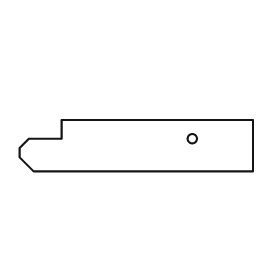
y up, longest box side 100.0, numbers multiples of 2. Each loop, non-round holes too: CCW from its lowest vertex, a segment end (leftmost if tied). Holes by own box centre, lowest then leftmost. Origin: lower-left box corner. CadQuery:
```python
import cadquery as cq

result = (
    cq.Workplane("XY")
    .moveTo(6.0, 0.0)
    .lineTo(100.0, 0.0)
    .lineTo(100.0, 22.0)
    .lineTo(18.0, 22.0)
    .lineTo(18.0, 14.0)
    .lineTo(4.0, 14.0)
    .lineTo(0.0, 10.0)
    .lineTo(0.0, 6.0)
    .close()
    .moveTo(74.0, 14.0)
    .circle(2.0)
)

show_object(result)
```